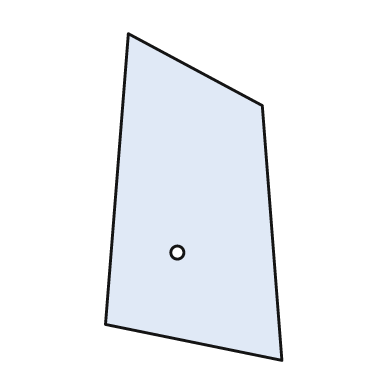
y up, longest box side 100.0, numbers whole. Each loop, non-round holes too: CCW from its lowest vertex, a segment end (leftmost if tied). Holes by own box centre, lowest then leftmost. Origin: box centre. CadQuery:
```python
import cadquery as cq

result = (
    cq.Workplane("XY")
    .moveTo(27.0, -50.0)
    .lineTo(21.0, 28.0)
    .lineTo(-20.0, 50.0)
    .lineTo(-27.0, -39.0)
    .close()
    .moveTo(-5.0, -17.0)
    .circle(2.0)
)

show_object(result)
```